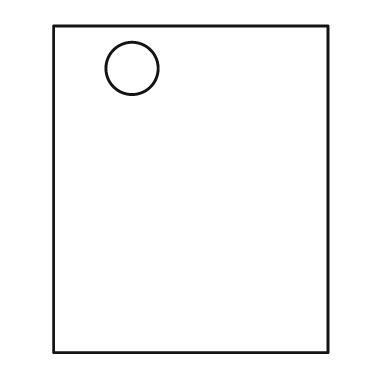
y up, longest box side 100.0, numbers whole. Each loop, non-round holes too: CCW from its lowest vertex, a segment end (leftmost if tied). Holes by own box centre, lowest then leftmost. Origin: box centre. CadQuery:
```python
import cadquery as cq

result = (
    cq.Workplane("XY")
    .moveTo(-42.0, -50.0)
    .lineTo(42.0, -50.0)
    .lineTo(42.0, 50.0)
    .lineTo(-42.0, 50.0)
    .close()
    .moveTo(-18.0, 37.0)
    .circle(8.0)
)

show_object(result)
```